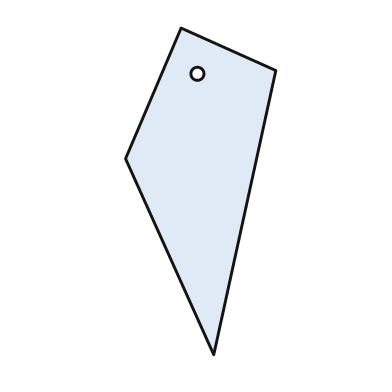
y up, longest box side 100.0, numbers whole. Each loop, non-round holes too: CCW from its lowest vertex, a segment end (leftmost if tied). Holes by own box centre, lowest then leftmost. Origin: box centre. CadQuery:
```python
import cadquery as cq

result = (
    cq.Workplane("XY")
    .moveTo(4.0, -50.0)
    .lineTo(23.0, 37.0)
    .lineTo(-6.0, 50.0)
    .lineTo(-23.0, 10.0)
    .close()
    .moveTo(-1.0, 36.0)
    .circle(2.0)
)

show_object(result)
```